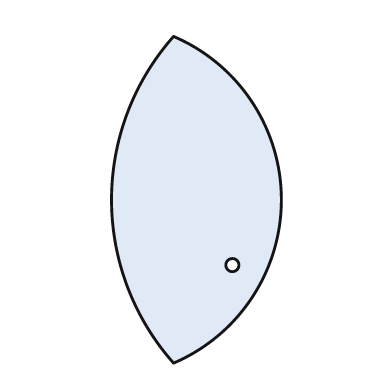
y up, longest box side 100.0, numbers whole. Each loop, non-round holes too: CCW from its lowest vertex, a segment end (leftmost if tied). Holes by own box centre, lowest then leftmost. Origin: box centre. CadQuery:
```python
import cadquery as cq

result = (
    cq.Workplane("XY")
    .moveTo(-7.0, -50.0)
    .threePointArc((26.0, 0.0), (-7.0, 50.0))
    .threePointArc((-26.0, 0.0), (-7.0, -50.0))
    .close()
    .moveTo(11.0, -20.0)
    .circle(2.0)
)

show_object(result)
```